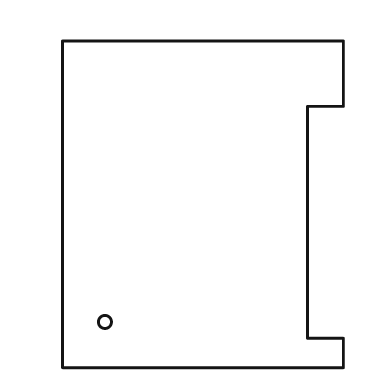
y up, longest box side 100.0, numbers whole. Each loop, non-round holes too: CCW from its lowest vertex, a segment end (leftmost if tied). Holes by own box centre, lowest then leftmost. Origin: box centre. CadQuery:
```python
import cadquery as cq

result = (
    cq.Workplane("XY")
    .moveTo(-43.0, -50.0)
    .lineTo(43.0, -50.0)
    .lineTo(43.0, -41.0)
    .lineTo(32.0, -41.0)
    .lineTo(32.0, 30.0)
    .lineTo(43.0, 30.0)
    .lineTo(43.0, 50.0)
    .lineTo(-43.0, 50.0)
    .close()
    .moveTo(-30.0, -36.0)
    .circle(2.0)
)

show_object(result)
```